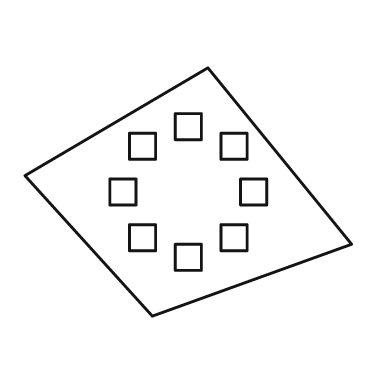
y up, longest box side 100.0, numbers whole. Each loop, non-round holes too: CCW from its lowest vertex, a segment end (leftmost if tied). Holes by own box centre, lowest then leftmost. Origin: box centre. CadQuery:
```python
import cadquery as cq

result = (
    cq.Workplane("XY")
    .moveTo(-11.0, -38.0)
    .lineTo(50.0, -16.0)
    .lineTo(6.0, 38.0)
    .lineTo(-50.0, 5.0)
    .close()
    .moveTo(-4.0, -24.0)
    .lineTo(4.0, -24.0)
    .lineTo(4.0, -16.0)
    .lineTo(-4.0, -16.0)
    .close()
    .moveTo(-18.0, -18.0)
    .lineTo(-10.0, -18.0)
    .lineTo(-10.0, -10.0)
    .lineTo(-18.0, -10.0)
    .close()
    .moveTo(10.0, -18.0)
    .lineTo(18.0, -18.0)
    .lineTo(18.0, -10.0)
    .lineTo(10.0, -10.0)
    .close()
    .moveTo(-24.0, -4.0)
    .lineTo(-16.0, -4.0)
    .lineTo(-16.0, 4.0)
    .lineTo(-24.0, 4.0)
    .close()
    .moveTo(16.0, -4.0)
    .lineTo(24.0, -4.0)
    .lineTo(24.0, 4.0)
    .lineTo(16.0, 4.0)
    .close()
    .moveTo(-18.0, 10.0)
    .lineTo(-10.0, 10.0)
    .lineTo(-10.0, 18.0)
    .lineTo(-18.0, 18.0)
    .close()
    .moveTo(10.0, 10.0)
    .lineTo(18.0, 10.0)
    .lineTo(18.0, 18.0)
    .lineTo(10.0, 18.0)
    .close()
    .moveTo(-4.0, 16.0)
    .lineTo(4.0, 16.0)
    .lineTo(4.0, 24.0)
    .lineTo(-4.0, 24.0)
    .close()
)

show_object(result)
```